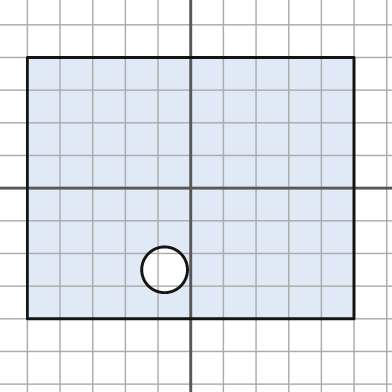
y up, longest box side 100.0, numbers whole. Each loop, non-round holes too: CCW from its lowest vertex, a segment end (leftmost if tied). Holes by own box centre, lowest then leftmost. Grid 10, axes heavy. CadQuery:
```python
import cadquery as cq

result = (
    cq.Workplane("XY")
    .moveTo(-50.0, -40.0)
    .lineTo(50.0, -40.0)
    .lineTo(50.0, 40.0)
    .lineTo(-50.0, 40.0)
    .close()
    .moveTo(-8.0, -25.0)
    .circle(7.0)
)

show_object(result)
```